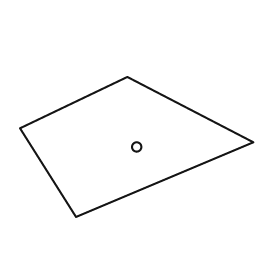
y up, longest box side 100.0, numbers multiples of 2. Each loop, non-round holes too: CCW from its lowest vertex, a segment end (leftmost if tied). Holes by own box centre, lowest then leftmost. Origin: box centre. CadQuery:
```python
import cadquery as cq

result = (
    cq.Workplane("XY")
    .moveTo(-26.0, -30.0)
    .lineTo(50.0, 2.0)
    .lineTo(-4.0, 30.0)
    .lineTo(-50.0, 8.0)
    .close()
    .moveTo(0.0, 0.0)
    .circle(2.0)
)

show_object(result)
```